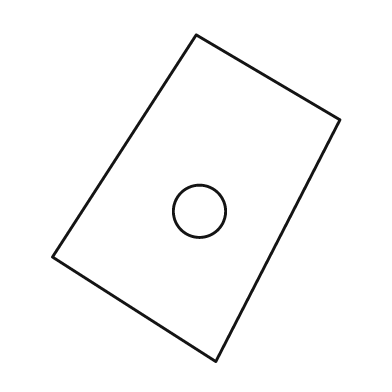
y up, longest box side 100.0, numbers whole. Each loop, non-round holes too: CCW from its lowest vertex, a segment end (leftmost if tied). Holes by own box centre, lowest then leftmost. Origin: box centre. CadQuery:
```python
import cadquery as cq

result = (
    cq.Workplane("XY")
    .moveTo(6.0, -50.0)
    .lineTo(44.0, 24.0)
    .lineTo(0.0, 50.0)
    .lineTo(-44.0, -18.0)
    .close()
    .moveTo(1.0, -4.0)
    .circle(8.0)
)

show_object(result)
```